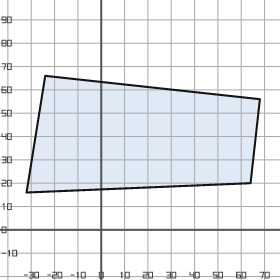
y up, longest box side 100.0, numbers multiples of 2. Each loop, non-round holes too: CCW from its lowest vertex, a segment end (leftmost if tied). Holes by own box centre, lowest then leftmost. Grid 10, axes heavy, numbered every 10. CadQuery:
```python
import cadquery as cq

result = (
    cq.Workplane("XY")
    .moveTo(-32.0, 16.0)
    .lineTo(64.0, 20.0)
    .lineTo(68.0, 56.0)
    .lineTo(-24.0, 66.0)
    .close()
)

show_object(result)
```